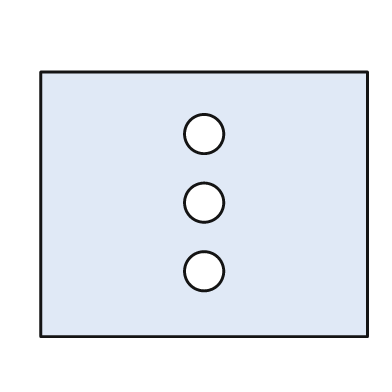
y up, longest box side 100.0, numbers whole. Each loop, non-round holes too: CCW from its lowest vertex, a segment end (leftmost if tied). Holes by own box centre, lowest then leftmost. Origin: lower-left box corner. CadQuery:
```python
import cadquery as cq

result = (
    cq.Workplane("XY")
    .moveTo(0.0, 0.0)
    .lineTo(100.0, 0.0)
    .lineTo(100.0, 81.0)
    .lineTo(0.0, 81.0)
    .close()
    .moveTo(50.0, 20.0)
    .circle(6.0)
    .moveTo(50.0, 41.0)
    .circle(6.0)
    .moveTo(50.0, 62.0)
    .circle(6.0)
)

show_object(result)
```